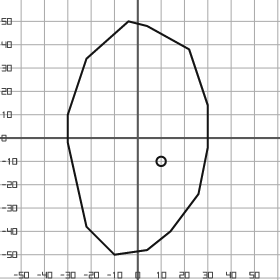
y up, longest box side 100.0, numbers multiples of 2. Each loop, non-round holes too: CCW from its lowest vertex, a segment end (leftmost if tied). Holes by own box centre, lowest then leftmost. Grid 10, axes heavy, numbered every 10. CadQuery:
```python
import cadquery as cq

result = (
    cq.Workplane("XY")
    .moveTo(-10.0, -50.0)
    .lineTo(4.0, -48.0)
    .lineTo(14.0, -40.0)
    .lineTo(26.0, -24.0)
    .lineTo(30.0, -4.0)
    .lineTo(30.0, 14.0)
    .lineTo(22.0, 38.0)
    .lineTo(4.0, 48.0)
    .lineTo(-4.0, 50.0)
    .lineTo(-22.0, 34.0)
    .lineTo(-30.0, 10.0)
    .lineTo(-30.0, -2.0)
    .lineTo(-22.0, -38.0)
    .close()
    .moveTo(10.0, -10.0)
    .circle(2.0)
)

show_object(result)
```